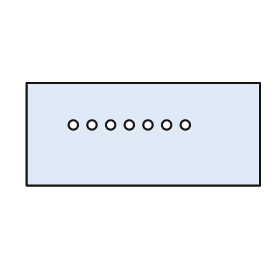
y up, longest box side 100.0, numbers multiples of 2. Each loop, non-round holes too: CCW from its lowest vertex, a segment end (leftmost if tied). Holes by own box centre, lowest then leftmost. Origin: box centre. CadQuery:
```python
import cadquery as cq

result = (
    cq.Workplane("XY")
    .moveTo(-50.0, -22.0)
    .lineTo(50.0, -22.0)
    .lineTo(50.0, 22.0)
    .lineTo(-50.0, 22.0)
    .close()
    .moveTo(-30.0, 4.0)
    .circle(2.0)
    .moveTo(-22.0, 4.0)
    .circle(2.0)
    .moveTo(-14.0, 4.0)
    .circle(2.0)
    .moveTo(-6.0, 4.0)
    .circle(2.0)
    .moveTo(2.0, 4.0)
    .circle(2.0)
    .moveTo(10.0, 4.0)
    .circle(2.0)
    .moveTo(18.0, 4.0)
    .circle(2.0)
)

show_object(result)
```